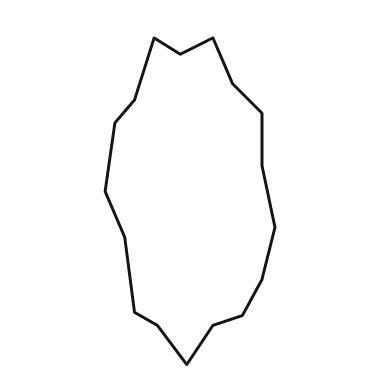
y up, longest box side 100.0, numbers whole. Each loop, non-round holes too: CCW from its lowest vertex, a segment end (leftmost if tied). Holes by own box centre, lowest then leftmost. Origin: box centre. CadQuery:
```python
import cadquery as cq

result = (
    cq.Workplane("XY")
    .moveTo(-1.0, -50.0)
    .lineTo(7.0, -38.0)
    .lineTo(16.0, -35.0)
    .lineTo(22.0, -24.0)
    .lineTo(26.0, -8.0)
    .lineTo(22.0, 11.0)
    .lineTo(22.0, 27.0)
    .lineTo(13.0, 36.0)
    .lineTo(7.0, 50.0)
    .lineTo(-3.0, 45.0)
    .lineTo(-11.0, 50.0)
    .lineTo(-17.0, 31.0)
    .lineTo(-23.0, 24.0)
    .lineTo(-26.0, 3.0)
    .lineTo(-20.0, -11.0)
    .lineTo(-17.0, -34.0)
    .lineTo(-10.0, -38.0)
    .close()
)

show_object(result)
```